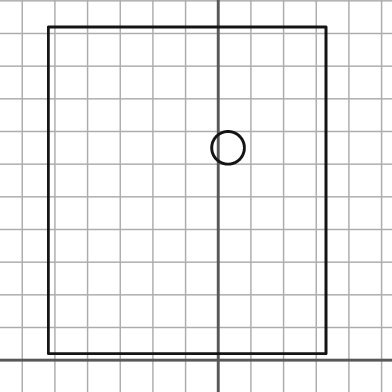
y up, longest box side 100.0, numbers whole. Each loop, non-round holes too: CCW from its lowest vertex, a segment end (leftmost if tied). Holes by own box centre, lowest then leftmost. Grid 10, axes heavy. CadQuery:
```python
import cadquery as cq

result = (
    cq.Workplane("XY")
    .moveTo(-52.0, 2.0)
    .lineTo(33.0, 2.0)
    .lineTo(33.0, 102.0)
    .lineTo(-52.0, 102.0)
    .close()
    .moveTo(3.0, 65.0)
    .circle(5.0)
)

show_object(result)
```